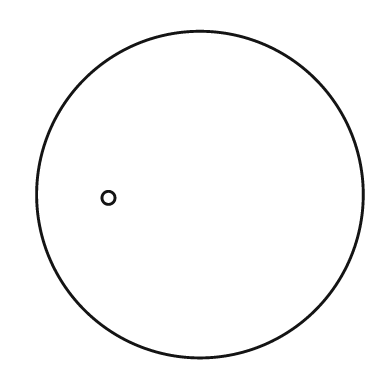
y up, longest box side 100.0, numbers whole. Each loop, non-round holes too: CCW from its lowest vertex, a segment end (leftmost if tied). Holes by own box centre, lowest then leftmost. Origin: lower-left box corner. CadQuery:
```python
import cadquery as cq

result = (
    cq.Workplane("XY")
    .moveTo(50.0, 50.0)
    .circle(50.0)
    .moveTo(22.0, 49.0)
    .circle(2.0)
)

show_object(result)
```